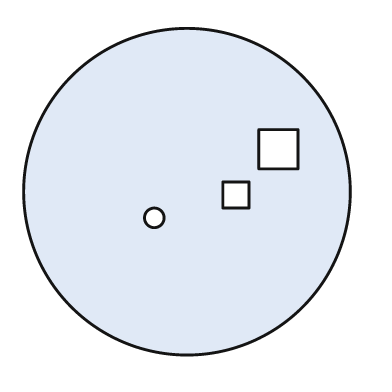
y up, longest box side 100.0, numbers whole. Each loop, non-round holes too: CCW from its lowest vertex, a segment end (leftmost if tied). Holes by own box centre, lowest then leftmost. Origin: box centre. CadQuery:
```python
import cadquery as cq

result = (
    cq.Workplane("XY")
    .moveTo(0.0, 0.0)
    .circle(50.0)
    .moveTo(-10.0, -8.0)
    .circle(3.0)
    .moveTo(11.0, -5.0)
    .lineTo(19.0, -5.0)
    .lineTo(19.0, 3.0)
    .lineTo(11.0, 3.0)
    .close()
    .moveTo(22.0, 7.0)
    .lineTo(34.0, 7.0)
    .lineTo(34.0, 19.0)
    .lineTo(22.0, 19.0)
    .close()
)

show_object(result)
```